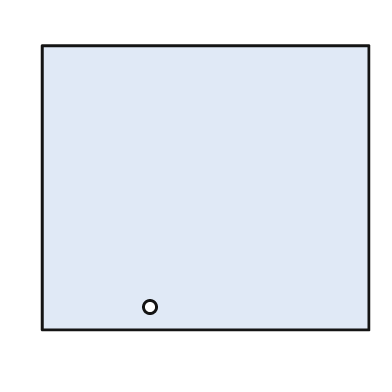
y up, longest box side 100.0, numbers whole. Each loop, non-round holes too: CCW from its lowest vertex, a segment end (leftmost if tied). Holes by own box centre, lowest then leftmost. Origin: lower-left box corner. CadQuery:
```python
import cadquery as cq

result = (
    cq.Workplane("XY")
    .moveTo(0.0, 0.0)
    .lineTo(100.0, 0.0)
    .lineTo(100.0, 87.0)
    .lineTo(0.0, 87.0)
    .close()
    .moveTo(33.0, 7.0)
    .circle(2.0)
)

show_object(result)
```